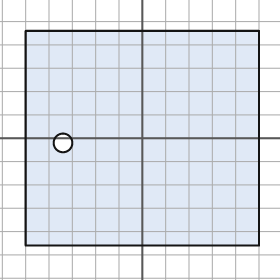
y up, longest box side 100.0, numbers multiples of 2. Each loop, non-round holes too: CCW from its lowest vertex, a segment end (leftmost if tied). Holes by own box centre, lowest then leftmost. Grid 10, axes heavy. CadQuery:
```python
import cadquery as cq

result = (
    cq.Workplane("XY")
    .moveTo(-50.0, -46.0)
    .lineTo(50.0, -46.0)
    .lineTo(50.0, 46.0)
    .lineTo(-50.0, 46.0)
    .close()
    .moveTo(-34.0, -2.0)
    .circle(4.0)
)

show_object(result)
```